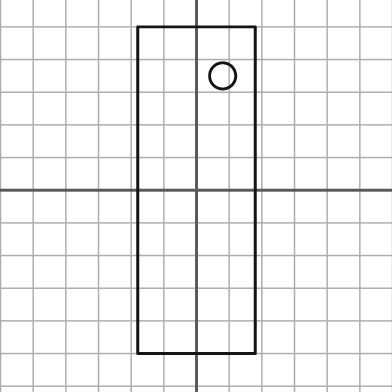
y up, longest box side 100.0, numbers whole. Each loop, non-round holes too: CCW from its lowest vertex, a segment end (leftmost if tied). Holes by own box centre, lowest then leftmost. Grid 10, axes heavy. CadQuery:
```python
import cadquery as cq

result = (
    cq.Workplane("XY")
    .moveTo(-18.0, -50.0)
    .lineTo(18.0, -50.0)
    .lineTo(18.0, 50.0)
    .lineTo(-18.0, 50.0)
    .close()
    .moveTo(8.0, 35.0)
    .circle(4.0)
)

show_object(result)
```